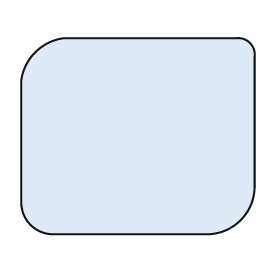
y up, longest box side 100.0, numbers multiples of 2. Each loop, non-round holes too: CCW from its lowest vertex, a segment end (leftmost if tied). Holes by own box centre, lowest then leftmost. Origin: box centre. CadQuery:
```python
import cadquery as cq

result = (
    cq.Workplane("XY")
    .moveTo(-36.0, -42.0)
    .lineTo(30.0, -42.0)
    .threePointArc((44.0, -36.0), (50.0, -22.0))
    .lineTo(50.0, 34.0)
    .threePointArc((48.0, 40.0), (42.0, 42.0))
    .lineTo(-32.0, 42.0)
    .threePointArc((-44.0, 36.0), (-50.0, 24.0))
    .lineTo(-50.0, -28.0)
    .threePointArc((-46.0, -38.0), (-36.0, -42.0))
    .close()
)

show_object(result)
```